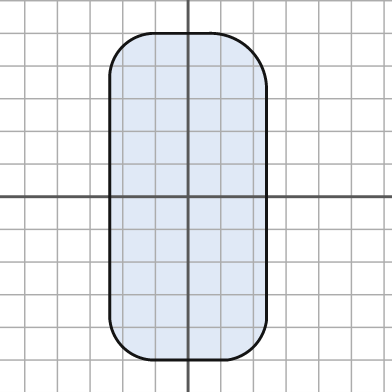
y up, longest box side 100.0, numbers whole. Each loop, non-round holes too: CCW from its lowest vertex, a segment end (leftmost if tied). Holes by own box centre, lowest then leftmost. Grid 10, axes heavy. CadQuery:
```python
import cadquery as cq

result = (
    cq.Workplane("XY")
    .moveTo(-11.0, -50.0)
    .lineTo(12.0, -50.0)
    .threePointArc((20.0, -46.0), (24.0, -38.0))
    .lineTo(24.0, 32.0)
    .threePointArc((19.0, 45.0), (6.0, 50.0))
    .lineTo(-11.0, 50.0)
    .threePointArc((-20.0, 46.0), (-24.0, 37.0))
    .lineTo(-24.0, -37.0)
    .threePointArc((-20.0, -46.0), (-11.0, -50.0))
    .close()
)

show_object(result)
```